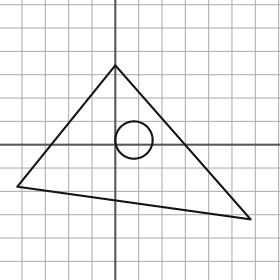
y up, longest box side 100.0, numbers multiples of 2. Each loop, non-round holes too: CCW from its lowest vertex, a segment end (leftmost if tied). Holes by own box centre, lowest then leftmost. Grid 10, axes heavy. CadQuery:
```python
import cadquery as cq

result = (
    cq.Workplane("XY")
    .moveTo(58.0, -32.0)
    .lineTo(0.0, 34.0)
    .lineTo(-42.0, -18.0)
    .close()
    .moveTo(8.0, 2.0)
    .circle(8.0)
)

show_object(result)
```